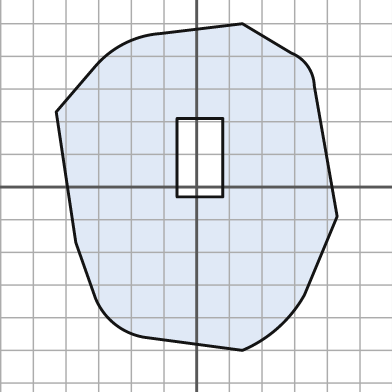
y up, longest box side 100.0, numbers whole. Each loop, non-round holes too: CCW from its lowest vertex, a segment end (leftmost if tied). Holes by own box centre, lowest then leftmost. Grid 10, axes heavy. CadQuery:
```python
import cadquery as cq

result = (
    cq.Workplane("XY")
    .moveTo(14.0, -50.0)
    .threePointArc((25.0, -43.0), (33.0, -33.0))
    .lineTo(43.0, -9.0)
    .lineTo(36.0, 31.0)
    .threePointArc((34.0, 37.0), (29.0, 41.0))
    .lineTo(14.0, 50.0)
    .lineTo(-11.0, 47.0)
    .threePointArc((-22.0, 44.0), (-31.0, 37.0))
    .lineTo(-43.0, 23.0)
    .lineTo(-37.0, -17.0)
    .lineTo(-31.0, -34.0)
    .threePointArc((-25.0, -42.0), (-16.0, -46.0))
    .close()
    .moveTo(-6.0, -3.0)
    .lineTo(8.0, -3.0)
    .lineTo(8.0, 21.0)
    .lineTo(-6.0, 21.0)
    .close()
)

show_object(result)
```